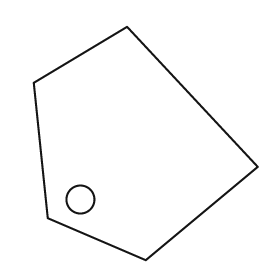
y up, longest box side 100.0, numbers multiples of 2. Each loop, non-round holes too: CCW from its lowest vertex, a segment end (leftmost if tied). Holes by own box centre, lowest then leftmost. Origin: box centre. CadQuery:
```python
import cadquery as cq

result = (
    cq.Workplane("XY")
    .moveTo(0.0, -50.0)
    .lineTo(48.0, -10.0)
    .lineTo(-8.0, 50.0)
    .lineTo(-48.0, 26.0)
    .lineTo(-42.0, -32.0)
    .close()
    .moveTo(-28.0, -24.0)
    .circle(6.0)
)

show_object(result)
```